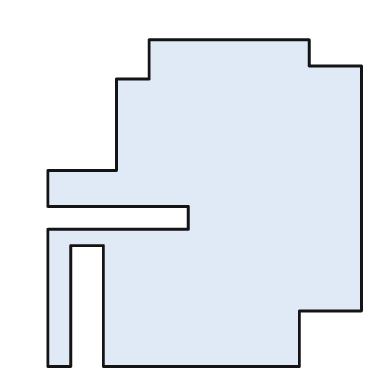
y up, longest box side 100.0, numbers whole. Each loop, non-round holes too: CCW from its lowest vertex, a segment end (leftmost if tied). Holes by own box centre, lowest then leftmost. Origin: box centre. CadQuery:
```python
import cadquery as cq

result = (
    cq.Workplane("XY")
    .moveTo(-48.0, -50.0)
    .lineTo(-41.0, -50.0)
    .lineTo(-41.0, -13.0)
    .lineTo(-31.0, -13.0)
    .lineTo(-31.0, -50.0)
    .lineTo(29.0, -50.0)
    .lineTo(29.0, -33.0)
    .lineTo(48.0, -33.0)
    .lineTo(48.0, 42.0)
    .lineTo(32.0, 42.0)
    .lineTo(32.0, 50.0)
    .lineTo(-17.0, 50.0)
    .lineTo(-17.0, 38.0)
    .lineTo(-27.0, 38.0)
    .lineTo(-27.0, 10.0)
    .lineTo(-48.0, 10.0)
    .lineTo(-48.0, -1.0)
    .lineTo(-5.0, -1.0)
    .lineTo(-5.0, -8.0)
    .lineTo(-48.0, -8.0)
    .close()
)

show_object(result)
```